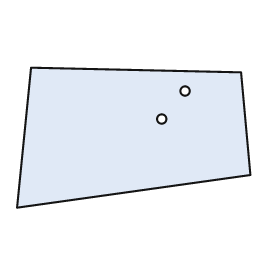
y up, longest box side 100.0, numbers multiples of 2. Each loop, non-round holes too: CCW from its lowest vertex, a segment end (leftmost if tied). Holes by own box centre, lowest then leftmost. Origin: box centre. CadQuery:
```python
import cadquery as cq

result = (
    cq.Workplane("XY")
    .moveTo(-50.0, -30.0)
    .lineTo(50.0, -16.0)
    .lineTo(46.0, 28.0)
    .lineTo(-44.0, 30.0)
    .close()
    .moveTo(12.0, 8.0)
    .circle(2.0)
    .moveTo(22.0, 20.0)
    .circle(2.0)
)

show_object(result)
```